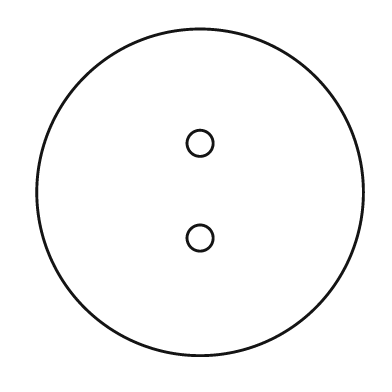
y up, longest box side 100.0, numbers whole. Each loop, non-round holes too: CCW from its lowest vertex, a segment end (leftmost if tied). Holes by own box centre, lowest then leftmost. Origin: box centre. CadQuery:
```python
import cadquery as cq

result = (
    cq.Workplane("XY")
    .moveTo(0.0, 0.0)
    .circle(50.0)
    .moveTo(0.0, -14.0)
    .circle(4.0)
    .moveTo(0.0, 15.0)
    .circle(4.0)
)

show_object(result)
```